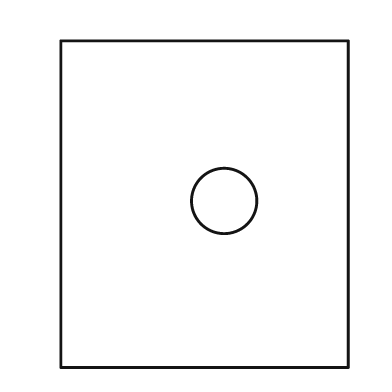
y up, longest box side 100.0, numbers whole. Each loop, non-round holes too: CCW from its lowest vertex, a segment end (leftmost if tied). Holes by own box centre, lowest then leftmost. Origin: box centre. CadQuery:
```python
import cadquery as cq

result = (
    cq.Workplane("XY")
    .moveTo(-44.0, -50.0)
    .lineTo(44.0, -50.0)
    .lineTo(44.0, 50.0)
    .lineTo(-44.0, 50.0)
    .close()
    .moveTo(6.0, 1.0)
    .circle(10.0)
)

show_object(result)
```